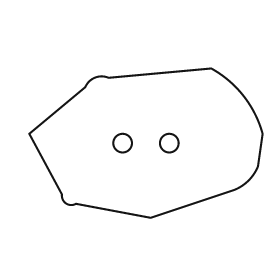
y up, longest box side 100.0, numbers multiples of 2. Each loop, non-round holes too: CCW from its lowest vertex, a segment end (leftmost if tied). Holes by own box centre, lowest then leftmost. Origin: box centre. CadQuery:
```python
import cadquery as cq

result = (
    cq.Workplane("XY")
    .moveTo(2.0, -32.0)
    .lineTo(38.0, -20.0)
    .threePointArc((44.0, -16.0), (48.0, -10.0))
    .lineTo(50.0, 4.0)
    .threePointArc((42.0, 20.0), (28.0, 32.0))
    .lineTo(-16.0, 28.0)
    .threePointArc((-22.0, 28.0), (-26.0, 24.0))
    .lineTo(-50.0, 4.0)
    .lineTo(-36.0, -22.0)
    .threePointArc((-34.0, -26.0), (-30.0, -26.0))
    .close()
    .moveTo(-10.0, 0.0)
    .circle(4.0)
    .moveTo(10.0, 0.0)
    .circle(4.0)
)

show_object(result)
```